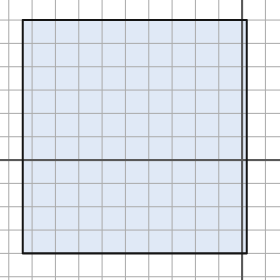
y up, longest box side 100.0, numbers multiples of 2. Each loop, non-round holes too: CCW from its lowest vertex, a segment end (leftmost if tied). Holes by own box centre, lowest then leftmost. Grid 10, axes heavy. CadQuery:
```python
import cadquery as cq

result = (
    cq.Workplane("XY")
    .moveTo(-94.0, -40.0)
    .lineTo(2.0, -40.0)
    .lineTo(2.0, 60.0)
    .lineTo(-94.0, 60.0)
    .close()
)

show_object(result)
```